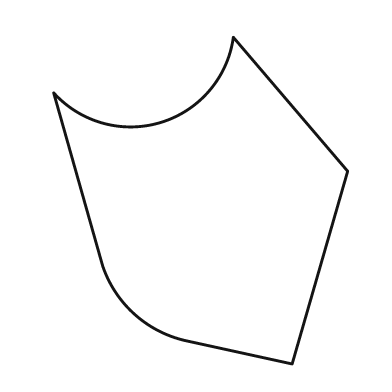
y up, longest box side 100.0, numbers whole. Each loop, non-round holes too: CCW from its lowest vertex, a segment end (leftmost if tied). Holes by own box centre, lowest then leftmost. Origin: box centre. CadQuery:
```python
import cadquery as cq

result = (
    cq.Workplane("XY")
    .moveTo(28.0, -50.0)
    .lineTo(45.0, 9.0)
    .lineTo(10.0, 50.0)
    .threePointArc((-12.0, 24.0), (-45.0, 33.0))
    .lineTo(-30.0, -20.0)
    .threePointArc((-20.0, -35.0), (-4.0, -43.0))
    .close()
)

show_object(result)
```